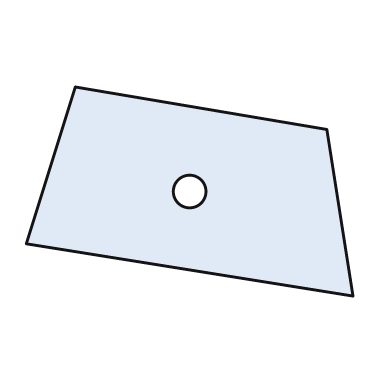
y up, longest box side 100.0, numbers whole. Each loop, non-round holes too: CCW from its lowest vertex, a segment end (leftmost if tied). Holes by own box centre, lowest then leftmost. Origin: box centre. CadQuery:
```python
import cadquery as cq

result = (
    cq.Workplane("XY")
    .moveTo(50.0, -32.0)
    .lineTo(42.0, 19.0)
    .lineTo(-35.0, 32.0)
    .lineTo(-50.0, -16.0)
    .close()
    .moveTo(0.0, 0.0)
    .circle(5.0)
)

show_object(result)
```